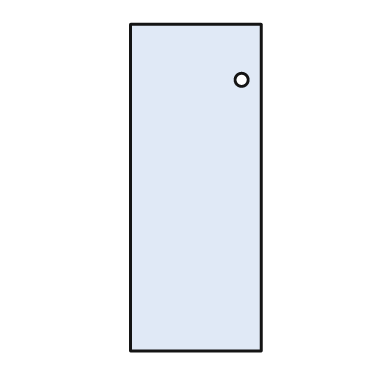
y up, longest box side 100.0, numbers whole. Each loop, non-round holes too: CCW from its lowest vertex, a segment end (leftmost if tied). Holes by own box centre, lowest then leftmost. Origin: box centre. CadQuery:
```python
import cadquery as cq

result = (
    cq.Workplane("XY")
    .moveTo(-20.0, -50.0)
    .lineTo(20.0, -50.0)
    .lineTo(20.0, 50.0)
    .lineTo(-20.0, 50.0)
    .close()
    .moveTo(14.0, 33.0)
    .circle(2.0)
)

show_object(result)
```